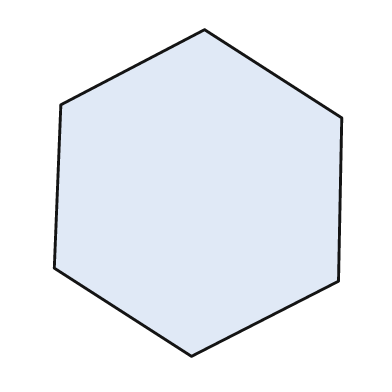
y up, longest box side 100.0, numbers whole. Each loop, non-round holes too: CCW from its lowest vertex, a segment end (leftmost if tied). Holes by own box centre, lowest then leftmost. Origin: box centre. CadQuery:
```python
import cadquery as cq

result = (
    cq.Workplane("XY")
    .moveTo(-2.0, -50.0)
    .lineTo(43.0, -27.0)
    .lineTo(44.0, 23.0)
    .lineTo(2.0, 50.0)
    .lineTo(-42.0, 27.0)
    .lineTo(-44.0, -23.0)
    .close()
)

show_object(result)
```